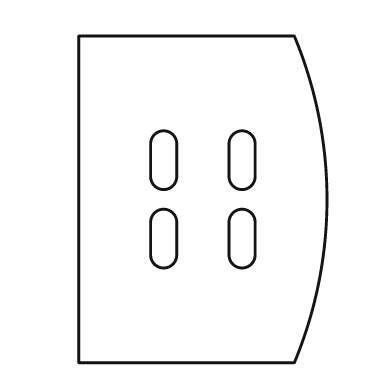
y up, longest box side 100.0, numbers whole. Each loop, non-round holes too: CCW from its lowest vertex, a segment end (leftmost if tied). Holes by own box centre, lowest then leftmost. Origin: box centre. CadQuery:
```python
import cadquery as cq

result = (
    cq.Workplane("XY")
    .moveTo(-38.0, -50.0)
    .lineTo(28.0, -50.0)
    .threePointArc((38.0, 0.0), (28.0, 50.0))
    .lineTo(-38.0, 50.0)
    .close()
    .moveTo(-16.0, -17.0)
    .threePointArc((-12.0, -21.0), (-8.0, -17.0))
    .lineTo(-8.0, -7.0)
    .threePointArc((-12.0, -3.0), (-16.0, -7.0))
    .close()
    .moveTo(8.0, -17.0)
    .threePointArc((12.0, -21.0), (16.0, -17.0))
    .lineTo(16.0, -7.0)
    .threePointArc((12.0, -3.0), (8.0, -7.0))
    .close()
    .moveTo(-16.0, 7.0)
    .threePointArc((-12.0, 3.0), (-8.0, 7.0))
    .lineTo(-8.0, 17.0)
    .threePointArc((-12.0, 21.0), (-16.0, 17.0))
    .close()
    .moveTo(8.0, 7.0)
    .threePointArc((12.0, 3.0), (16.0, 7.0))
    .lineTo(16.0, 17.0)
    .threePointArc((12.0, 21.0), (8.0, 17.0))
    .close()
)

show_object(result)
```